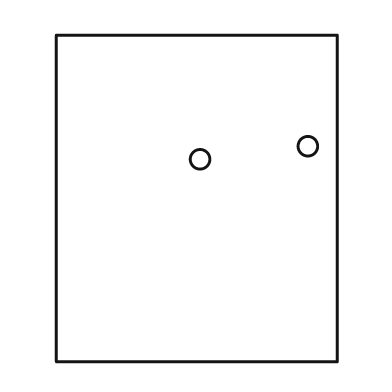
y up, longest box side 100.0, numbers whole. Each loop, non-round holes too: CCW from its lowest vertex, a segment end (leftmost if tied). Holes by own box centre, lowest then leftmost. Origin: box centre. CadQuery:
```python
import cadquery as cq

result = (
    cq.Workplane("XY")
    .moveTo(-43.0, -50.0)
    .lineTo(43.0, -50.0)
    .lineTo(43.0, 50.0)
    .lineTo(-43.0, 50.0)
    .close()
    .moveTo(1.0, 12.0)
    .circle(3.0)
    .moveTo(34.0, 16.0)
    .circle(3.0)
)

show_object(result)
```